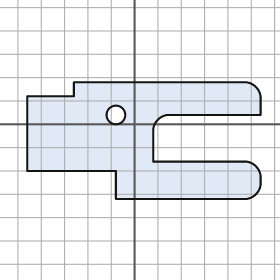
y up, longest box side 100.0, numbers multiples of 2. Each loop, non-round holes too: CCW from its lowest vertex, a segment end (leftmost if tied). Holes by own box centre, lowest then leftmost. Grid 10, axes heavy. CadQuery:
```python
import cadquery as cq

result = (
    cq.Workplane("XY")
    .moveTo(-8.0, -32.0)
    .lineTo(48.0, -32.0)
    .threePointArc((52.0, -30.0), (54.0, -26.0))
    .lineTo(54.0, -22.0)
    .threePointArc((52.0, -18.0), (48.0, -16.0))
    .lineTo(8.0, -16.0)
    .lineTo(8.0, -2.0)
    .threePointArc((10.0, 2.0), (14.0, 4.0))
    .lineTo(54.0, 4.0)
    .lineTo(54.0, 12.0)
    .threePointArc((52.0, 16.0), (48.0, 18.0))
    .lineTo(-26.0, 18.0)
    .lineTo(-26.0, 12.0)
    .lineTo(-46.0, 12.0)
    .lineTo(-46.0, -20.0)
    .lineTo(-8.0, -20.0)
    .close()
    .moveTo(-8.0, 4.0)
    .circle(4.0)
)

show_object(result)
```